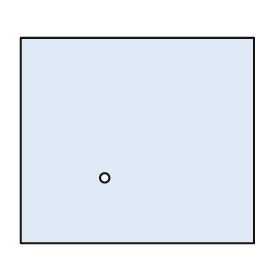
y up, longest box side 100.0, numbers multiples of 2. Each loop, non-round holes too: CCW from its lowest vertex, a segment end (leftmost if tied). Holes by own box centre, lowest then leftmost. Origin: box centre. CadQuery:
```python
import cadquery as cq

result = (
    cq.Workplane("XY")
    .moveTo(-50.0, -44.0)
    .lineTo(50.0, -44.0)
    .lineTo(50.0, 44.0)
    .lineTo(-50.0, 44.0)
    .close()
    .moveTo(-14.0, -16.0)
    .circle(2.0)
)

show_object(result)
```